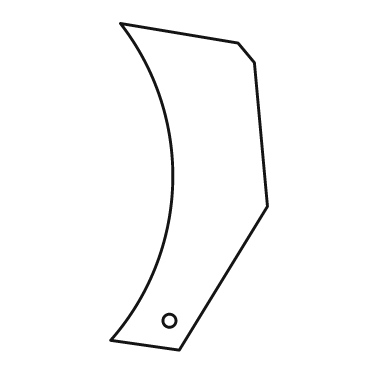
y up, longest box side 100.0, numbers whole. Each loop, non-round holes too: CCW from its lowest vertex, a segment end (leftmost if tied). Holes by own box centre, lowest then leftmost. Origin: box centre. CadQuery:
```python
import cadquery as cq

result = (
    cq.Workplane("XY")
    .moveTo(-3.0, -50.0)
    .lineTo(24.0, -6.0)
    .lineTo(20.0, 38.0)
    .lineTo(15.0, 44.0)
    .lineTo(-21.0, 50.0)
    .threePointArc((-5.0, 1.0), (-24.0, -47.0))
    .close()
    .moveTo(-6.0, -41.0)
    .circle(2.0)
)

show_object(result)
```